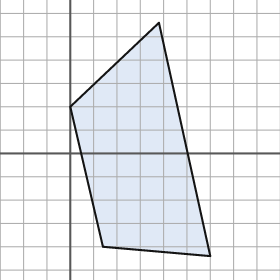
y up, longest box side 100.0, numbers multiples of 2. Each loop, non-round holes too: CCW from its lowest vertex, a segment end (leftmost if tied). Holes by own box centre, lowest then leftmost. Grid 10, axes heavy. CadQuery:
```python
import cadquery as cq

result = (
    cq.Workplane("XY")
    .moveTo(60.0, -44.0)
    .lineTo(38.0, 56.0)
    .lineTo(0.0, 20.0)
    .lineTo(14.0, -40.0)
    .close()
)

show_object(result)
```